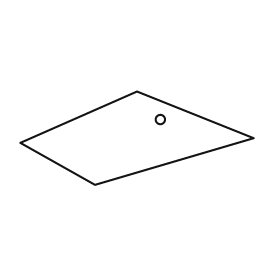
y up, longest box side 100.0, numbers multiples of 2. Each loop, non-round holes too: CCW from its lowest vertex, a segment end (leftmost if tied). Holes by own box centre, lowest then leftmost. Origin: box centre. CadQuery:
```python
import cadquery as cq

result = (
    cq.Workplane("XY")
    .moveTo(-18.0, -20.0)
    .lineTo(50.0, 0.0)
    .lineTo(0.0, 20.0)
    .lineTo(-50.0, -2.0)
    .close()
    .moveTo(10.0, 8.0)
    .circle(2.0)
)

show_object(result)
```